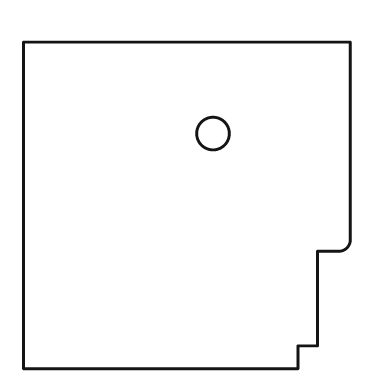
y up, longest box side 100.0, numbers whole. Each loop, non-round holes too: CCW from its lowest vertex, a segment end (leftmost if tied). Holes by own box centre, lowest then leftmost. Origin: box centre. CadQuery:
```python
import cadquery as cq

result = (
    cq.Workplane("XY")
    .moveTo(-50.0, -50.0)
    .lineTo(34.0, -50.0)
    .lineTo(34.0, -43.0)
    .lineTo(40.0, -43.0)
    .lineTo(40.0, -14.0)
    .lineTo(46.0, -14.0)
    .threePointArc((49.0, -13.0), (50.0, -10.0))
    .lineTo(50.0, 50.0)
    .lineTo(-50.0, 50.0)
    .close()
    .moveTo(8.0, 22.0)
    .circle(5.0)
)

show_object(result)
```